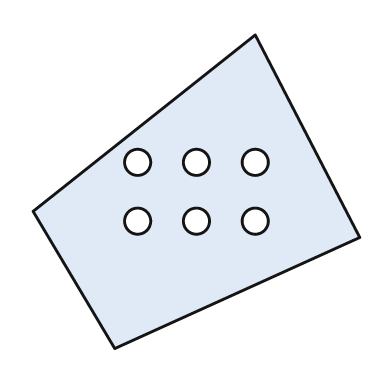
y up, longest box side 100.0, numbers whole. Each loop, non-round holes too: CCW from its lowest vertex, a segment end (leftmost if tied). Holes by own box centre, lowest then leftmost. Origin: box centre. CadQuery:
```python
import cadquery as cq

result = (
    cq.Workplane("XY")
    .moveTo(-25.0, -48.0)
    .lineTo(50.0, -14.0)
    .lineTo(18.0, 48.0)
    .lineTo(-50.0, -6.0)
    .close()
    .moveTo(-18.0, -9.0)
    .circle(4.0)
    .moveTo(0.0, -9.0)
    .circle(4.0)
    .moveTo(18.0, -9.0)
    .circle(4.0)
    .moveTo(-18.0, 9.0)
    .circle(4.0)
    .moveTo(0.0, 9.0)
    .circle(4.0)
    .moveTo(18.0, 9.0)
    .circle(4.0)
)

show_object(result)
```